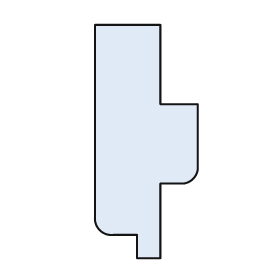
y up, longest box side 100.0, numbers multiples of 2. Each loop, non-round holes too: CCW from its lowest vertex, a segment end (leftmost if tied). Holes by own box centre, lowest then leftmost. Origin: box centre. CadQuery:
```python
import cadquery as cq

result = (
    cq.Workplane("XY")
    .moveTo(-4.0, -50.0)
    .lineTo(6.0, -50.0)
    .lineTo(6.0, -18.0)
    .lineTo(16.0, -18.0)
    .threePointArc((20.0, -16.0), (22.0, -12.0))
    .lineTo(22.0, 16.0)
    .lineTo(6.0, 16.0)
    .lineTo(6.0, 50.0)
    .lineTo(-22.0, 50.0)
    .lineTo(-22.0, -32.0)
    .threePointArc((-20.0, -38.0), (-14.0, -40.0))
    .lineTo(-4.0, -40.0)
    .close()
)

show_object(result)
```